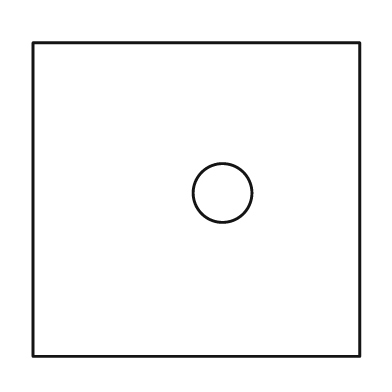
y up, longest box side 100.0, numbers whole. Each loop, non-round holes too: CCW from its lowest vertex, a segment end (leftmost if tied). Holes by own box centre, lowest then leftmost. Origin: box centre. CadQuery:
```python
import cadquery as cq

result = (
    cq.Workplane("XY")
    .moveTo(-50.0, -48.0)
    .lineTo(50.0, -48.0)
    .lineTo(50.0, 48.0)
    .lineTo(-50.0, 48.0)
    .close()
    .moveTo(8.0, 2.0)
    .circle(9.0)
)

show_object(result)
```